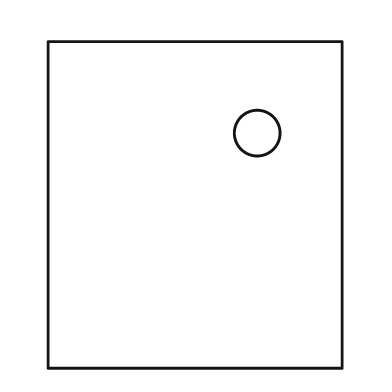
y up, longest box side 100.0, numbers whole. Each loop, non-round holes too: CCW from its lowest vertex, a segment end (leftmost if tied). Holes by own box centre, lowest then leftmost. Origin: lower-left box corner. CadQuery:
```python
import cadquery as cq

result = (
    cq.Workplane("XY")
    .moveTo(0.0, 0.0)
    .lineTo(90.0, 0.0)
    .lineTo(90.0, 100.0)
    .lineTo(0.0, 100.0)
    .close()
    .moveTo(64.0, 72.0)
    .circle(7.0)
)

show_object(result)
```